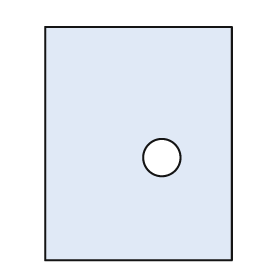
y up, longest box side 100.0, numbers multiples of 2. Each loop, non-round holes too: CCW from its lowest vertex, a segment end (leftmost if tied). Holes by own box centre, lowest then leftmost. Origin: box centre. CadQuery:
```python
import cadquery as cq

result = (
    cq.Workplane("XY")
    .moveTo(-40.0, -50.0)
    .lineTo(40.0, -50.0)
    .lineTo(40.0, 50.0)
    .lineTo(-40.0, 50.0)
    .close()
    .moveTo(10.0, -6.0)
    .circle(8.0)
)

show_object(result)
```